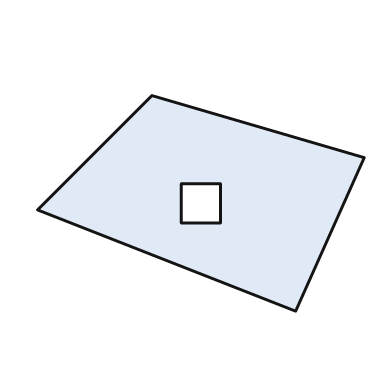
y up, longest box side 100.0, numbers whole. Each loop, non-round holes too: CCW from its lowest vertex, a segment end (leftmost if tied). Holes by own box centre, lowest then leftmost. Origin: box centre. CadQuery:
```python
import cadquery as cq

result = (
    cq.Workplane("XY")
    .moveTo(29.0, -33.0)
    .lineTo(50.0, 14.0)
    .lineTo(-15.0, 33.0)
    .lineTo(-50.0, -2.0)
    .close()
    .moveTo(-6.0, -6.0)
    .lineTo(6.0, -6.0)
    .lineTo(6.0, 6.0)
    .lineTo(-6.0, 6.0)
    .close()
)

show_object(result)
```